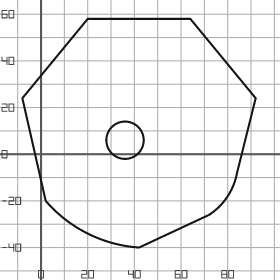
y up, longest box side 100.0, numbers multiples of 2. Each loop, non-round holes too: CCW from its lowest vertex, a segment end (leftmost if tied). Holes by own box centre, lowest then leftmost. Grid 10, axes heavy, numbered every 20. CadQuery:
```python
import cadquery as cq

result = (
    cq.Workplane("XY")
    .moveTo(42.0, -40.0)
    .lineTo(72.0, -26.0)
    .threePointArc((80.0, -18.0), (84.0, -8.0))
    .lineTo(92.0, 24.0)
    .lineTo(64.0, 58.0)
    .lineTo(20.0, 58.0)
    .lineTo(-8.0, 24.0)
    .lineTo(2.0, -20.0)
    .threePointArc((20.0, -34.0), (42.0, -40.0))
    .close()
    .moveTo(36.0, 6.0)
    .circle(8.0)
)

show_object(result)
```